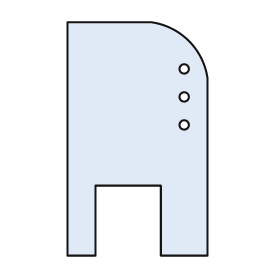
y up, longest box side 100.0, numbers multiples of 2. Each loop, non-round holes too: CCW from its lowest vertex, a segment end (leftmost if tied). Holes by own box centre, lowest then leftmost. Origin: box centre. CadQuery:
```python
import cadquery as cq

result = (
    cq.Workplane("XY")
    .moveTo(-30.0, -50.0)
    .lineTo(-18.0, -50.0)
    .lineTo(-18.0, -20.0)
    .lineTo(10.0, -20.0)
    .lineTo(10.0, -50.0)
    .lineTo(30.0, -50.0)
    .lineTo(30.0, 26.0)
    .threePointArc((22.0, 42.0), (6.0, 50.0))
    .lineTo(-30.0, 50.0)
    .close()
    .moveTo(20.0, 6.0)
    .circle(2.0)
    .moveTo(20.0, 18.0)
    .circle(2.0)
    .moveTo(20.0, 30.0)
    .circle(2.0)
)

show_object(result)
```